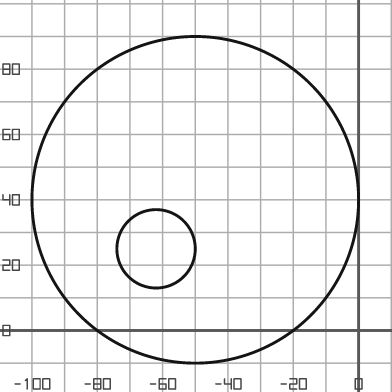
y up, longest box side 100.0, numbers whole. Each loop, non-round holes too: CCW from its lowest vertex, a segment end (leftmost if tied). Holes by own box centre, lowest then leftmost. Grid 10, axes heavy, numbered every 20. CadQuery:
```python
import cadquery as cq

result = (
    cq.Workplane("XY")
    .moveTo(-50.0, 40.0)
    .circle(50.0)
    .moveTo(-62.0, 25.0)
    .circle(12.0)
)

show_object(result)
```